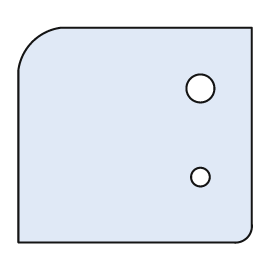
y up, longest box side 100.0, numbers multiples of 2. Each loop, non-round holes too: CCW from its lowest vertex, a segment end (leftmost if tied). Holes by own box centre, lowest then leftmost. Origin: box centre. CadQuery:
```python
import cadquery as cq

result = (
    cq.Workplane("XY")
    .moveTo(-50.0, -46.0)
    .lineTo(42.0, -46.0)
    .threePointArc((48.0, -44.0), (50.0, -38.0))
    .lineTo(50.0, 46.0)
    .lineTo(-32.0, 46.0)
    .threePointArc((-44.0, 40.0), (-50.0, 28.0))
    .close()
    .moveTo(28.0, -18.0)
    .circle(4.0)
    .moveTo(28.0, 20.0)
    .circle(6.0)
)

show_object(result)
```